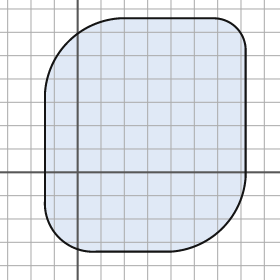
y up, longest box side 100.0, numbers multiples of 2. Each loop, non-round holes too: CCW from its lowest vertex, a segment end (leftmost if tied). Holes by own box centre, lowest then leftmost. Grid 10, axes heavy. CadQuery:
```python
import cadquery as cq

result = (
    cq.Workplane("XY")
    .moveTo(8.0, -34.0)
    .lineTo(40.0, -34.0)
    .threePointArc((62.0, -24.0), (72.0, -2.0))
    .lineTo(72.0, 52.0)
    .threePointArc((68.0, 62.0), (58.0, 66.0))
    .lineTo(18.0, 66.0)
    .threePointArc((-4.0, 56.0), (-14.0, 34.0))
    .lineTo(-14.0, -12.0)
    .threePointArc((-8.0, -28.0), (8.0, -34.0))
    .close()
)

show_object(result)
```